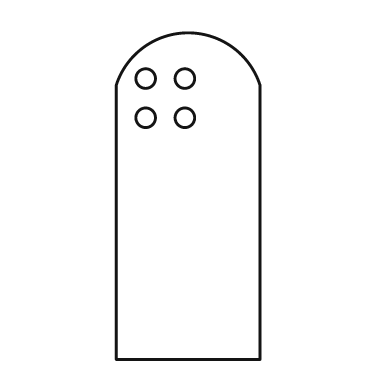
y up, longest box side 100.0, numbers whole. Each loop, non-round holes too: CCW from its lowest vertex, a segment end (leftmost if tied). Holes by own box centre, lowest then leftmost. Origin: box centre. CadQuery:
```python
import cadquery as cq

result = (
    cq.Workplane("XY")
    .moveTo(-22.0, -50.0)
    .lineTo(22.0, -50.0)
    .lineTo(22.0, 34.0)
    .threePointArc((0.0, 50.0), (-22.0, 34.0))
    .close()
    .moveTo(-13.0, 24.0)
    .circle(3.0)
    .moveTo(-1.0, 24.0)
    .circle(3.0)
    .moveTo(-13.0, 36.0)
    .circle(3.0)
    .moveTo(-1.0, 36.0)
    .circle(3.0)
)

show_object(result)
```